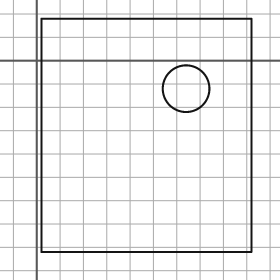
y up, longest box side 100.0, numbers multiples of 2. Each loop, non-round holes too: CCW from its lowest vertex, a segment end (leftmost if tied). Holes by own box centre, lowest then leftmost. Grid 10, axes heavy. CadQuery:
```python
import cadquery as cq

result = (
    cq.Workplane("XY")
    .moveTo(2.0, -82.0)
    .lineTo(92.0, -82.0)
    .lineTo(92.0, 18.0)
    .lineTo(2.0, 18.0)
    .close()
    .moveTo(64.0, -12.0)
    .circle(10.0)
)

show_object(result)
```